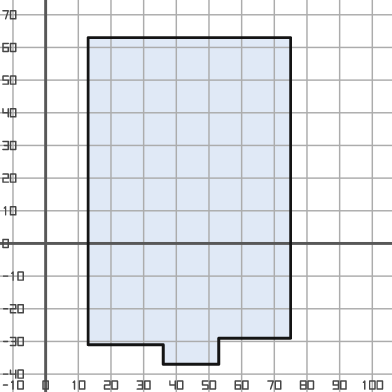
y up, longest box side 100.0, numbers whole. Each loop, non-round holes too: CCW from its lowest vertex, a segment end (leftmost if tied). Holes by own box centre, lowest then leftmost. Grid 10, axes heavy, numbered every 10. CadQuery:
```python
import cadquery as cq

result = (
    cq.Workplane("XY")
    .moveTo(36.0, -37.0)
    .lineTo(53.0, -37.0)
    .lineTo(53.0, -29.0)
    .lineTo(75.0, -29.0)
    .lineTo(75.0, 63.0)
    .lineTo(13.0, 63.0)
    .lineTo(13.0, -31.0)
    .lineTo(36.0, -31.0)
    .close()
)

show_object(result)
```